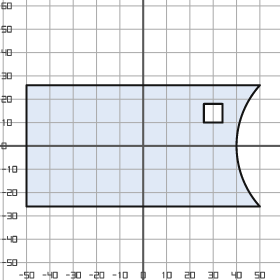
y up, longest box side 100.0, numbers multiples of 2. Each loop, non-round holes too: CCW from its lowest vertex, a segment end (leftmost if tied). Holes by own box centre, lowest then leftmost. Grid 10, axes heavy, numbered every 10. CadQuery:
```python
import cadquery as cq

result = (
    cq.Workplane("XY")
    .moveTo(-50.0, -26.0)
    .lineTo(50.0, -26.0)
    .threePointArc((40.0, 0.0), (50.0, 26.0))
    .lineTo(-50.0, 26.0)
    .close()
    .moveTo(26.0, 10.0)
    .lineTo(34.0, 10.0)
    .lineTo(34.0, 18.0)
    .lineTo(26.0, 18.0)
    .close()
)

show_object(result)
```